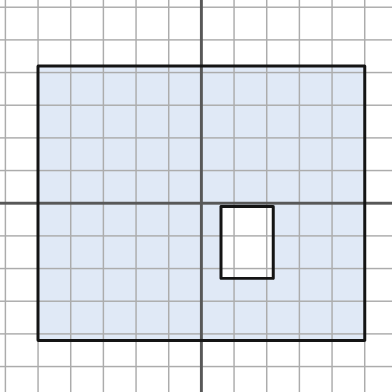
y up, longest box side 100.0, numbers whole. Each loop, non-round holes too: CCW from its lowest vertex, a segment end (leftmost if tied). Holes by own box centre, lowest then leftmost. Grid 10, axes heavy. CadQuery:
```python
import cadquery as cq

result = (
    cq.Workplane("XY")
    .moveTo(-50.0, -42.0)
    .lineTo(50.0, -42.0)
    .lineTo(50.0, 42.0)
    .lineTo(-50.0, 42.0)
    .close()
    .moveTo(6.0, -23.0)
    .lineTo(22.0, -23.0)
    .lineTo(22.0, -1.0)
    .lineTo(6.0, -1.0)
    .close()
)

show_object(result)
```